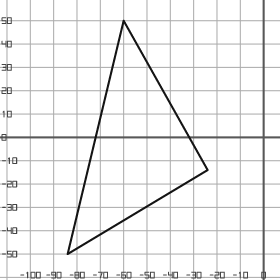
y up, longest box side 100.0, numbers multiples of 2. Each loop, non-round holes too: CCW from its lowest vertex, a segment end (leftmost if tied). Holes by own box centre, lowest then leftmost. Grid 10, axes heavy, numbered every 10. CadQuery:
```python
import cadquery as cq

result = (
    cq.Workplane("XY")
    .moveTo(-84.0, -50.0)
    .lineTo(-24.0, -14.0)
    .lineTo(-60.0, 50.0)
    .close()
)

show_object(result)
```